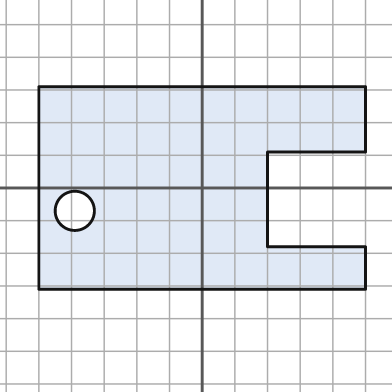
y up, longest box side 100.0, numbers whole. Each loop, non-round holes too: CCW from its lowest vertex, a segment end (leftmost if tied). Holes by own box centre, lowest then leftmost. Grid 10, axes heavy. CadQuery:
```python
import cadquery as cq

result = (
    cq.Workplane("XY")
    .moveTo(-50.0, -31.0)
    .lineTo(50.0, -31.0)
    .lineTo(50.0, -18.0)
    .lineTo(20.0, -18.0)
    .lineTo(20.0, 11.0)
    .lineTo(50.0, 11.0)
    .lineTo(50.0, 31.0)
    .lineTo(-50.0, 31.0)
    .close()
    .moveTo(-39.0, -7.0)
    .circle(6.0)
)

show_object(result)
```